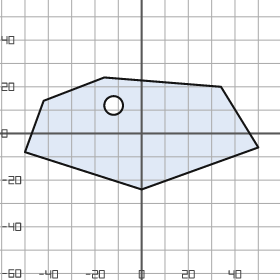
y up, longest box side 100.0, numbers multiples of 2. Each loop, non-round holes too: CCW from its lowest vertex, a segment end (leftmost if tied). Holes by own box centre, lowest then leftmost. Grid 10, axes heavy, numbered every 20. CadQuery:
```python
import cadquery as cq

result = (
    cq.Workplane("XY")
    .moveTo(0.0, -24.0)
    .lineTo(50.0, -6.0)
    .lineTo(34.0, 20.0)
    .lineTo(-16.0, 24.0)
    .lineTo(-42.0, 14.0)
    .lineTo(-50.0, -8.0)
    .close()
    .moveTo(-12.0, 12.0)
    .circle(4.0)
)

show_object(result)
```